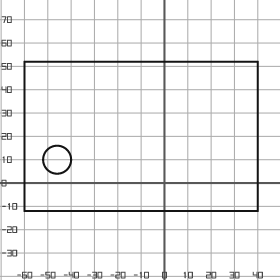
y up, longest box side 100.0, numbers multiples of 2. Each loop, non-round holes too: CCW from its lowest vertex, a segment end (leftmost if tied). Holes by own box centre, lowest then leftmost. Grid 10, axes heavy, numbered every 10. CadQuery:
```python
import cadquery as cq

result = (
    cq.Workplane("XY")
    .moveTo(-60.0, -12.0)
    .lineTo(40.0, -12.0)
    .lineTo(40.0, 52.0)
    .lineTo(-60.0, 52.0)
    .close()
    .moveTo(-46.0, 10.0)
    .circle(6.0)
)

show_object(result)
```